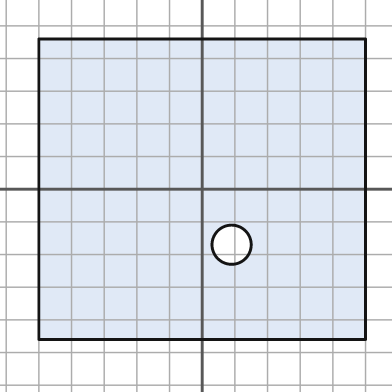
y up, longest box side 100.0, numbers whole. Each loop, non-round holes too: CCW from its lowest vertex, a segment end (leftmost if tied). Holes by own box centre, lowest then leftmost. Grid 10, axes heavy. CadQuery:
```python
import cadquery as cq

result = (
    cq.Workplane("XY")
    .moveTo(-50.0, -46.0)
    .lineTo(50.0, -46.0)
    .lineTo(50.0, 46.0)
    .lineTo(-50.0, 46.0)
    .close()
    .moveTo(9.0, -17.0)
    .circle(6.0)
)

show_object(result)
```